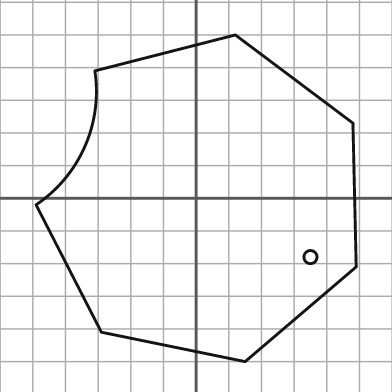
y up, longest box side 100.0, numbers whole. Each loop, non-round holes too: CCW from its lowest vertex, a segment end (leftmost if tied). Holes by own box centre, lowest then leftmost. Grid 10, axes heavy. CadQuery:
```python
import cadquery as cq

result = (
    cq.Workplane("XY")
    .moveTo(15.0, -50.0)
    .lineTo(49.0, -21.0)
    .lineTo(48.0, 23.0)
    .lineTo(12.0, 50.0)
    .lineTo(-31.0, 39.0)
    .threePointArc((-34.0, 16.0), (-49.0, -2.0))
    .lineTo(-29.0, -41.0)
    .close()
    .moveTo(35.0, -18.0)
    .circle(2.0)
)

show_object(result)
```